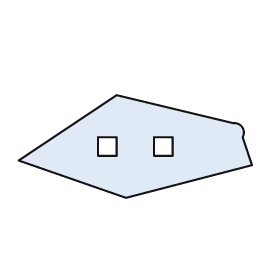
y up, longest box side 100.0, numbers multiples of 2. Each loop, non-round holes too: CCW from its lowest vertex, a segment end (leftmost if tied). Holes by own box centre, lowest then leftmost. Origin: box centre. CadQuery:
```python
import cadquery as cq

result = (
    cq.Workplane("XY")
    .moveTo(-4.0, -22.0)
    .lineTo(50.0, -8.0)
    .lineTo(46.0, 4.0)
    .threePointArc((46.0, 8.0), (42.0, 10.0))
    .lineTo(-8.0, 22.0)
    .lineTo(-50.0, -6.0)
    .close()
    .moveTo(-16.0, -4.0)
    .lineTo(-8.0, -4.0)
    .lineTo(-8.0, 4.0)
    .lineTo(-16.0, 4.0)
    .close()
    .moveTo(8.0, -4.0)
    .lineTo(16.0, -4.0)
    .lineTo(16.0, 4.0)
    .lineTo(8.0, 4.0)
    .close()
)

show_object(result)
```